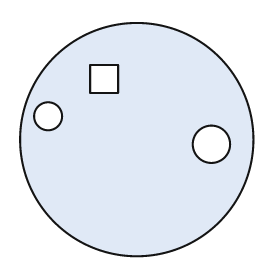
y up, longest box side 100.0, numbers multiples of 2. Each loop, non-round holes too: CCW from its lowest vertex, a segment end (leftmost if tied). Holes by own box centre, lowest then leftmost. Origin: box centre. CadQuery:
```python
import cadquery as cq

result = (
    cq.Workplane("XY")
    .moveTo(0.0, 0.0)
    .circle(50.0)
    .moveTo(32.0, -2.0)
    .circle(8.0)
    .moveTo(-38.0, 10.0)
    .circle(6.0)
    .moveTo(-20.0, 20.0)
    .lineTo(-8.0, 20.0)
    .lineTo(-8.0, 32.0)
    .lineTo(-20.0, 32.0)
    .close()
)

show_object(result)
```